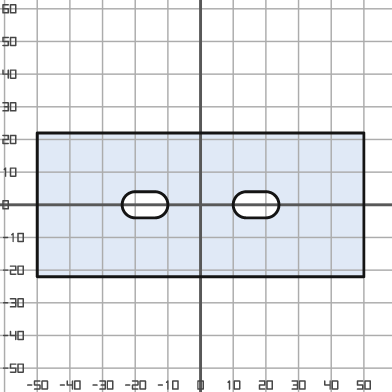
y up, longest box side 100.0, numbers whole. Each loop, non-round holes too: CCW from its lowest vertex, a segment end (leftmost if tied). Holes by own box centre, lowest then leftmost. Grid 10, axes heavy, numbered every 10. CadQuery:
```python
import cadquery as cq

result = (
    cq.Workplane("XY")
    .moveTo(-50.0, -22.0)
    .lineTo(50.0, -22.0)
    .lineTo(50.0, 22.0)
    .lineTo(-50.0, 22.0)
    .close()
    .moveTo(-20.0, -4.0)
    .lineTo(-14.0, -4.0)
    .threePointArc((-10.0, 0.0), (-14.0, 4.0))
    .lineTo(-20.0, 4.0)
    .threePointArc((-24.0, 0.0), (-20.0, -4.0))
    .close()
    .moveTo(14.0, -4.0)
    .lineTo(20.0, -4.0)
    .threePointArc((24.0, 0.0), (20.0, 4.0))
    .lineTo(14.0, 4.0)
    .threePointArc((10.0, 0.0), (14.0, -4.0))
    .close()
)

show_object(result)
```